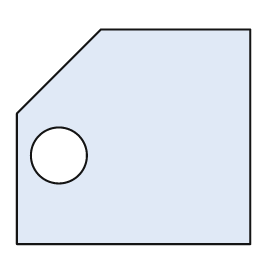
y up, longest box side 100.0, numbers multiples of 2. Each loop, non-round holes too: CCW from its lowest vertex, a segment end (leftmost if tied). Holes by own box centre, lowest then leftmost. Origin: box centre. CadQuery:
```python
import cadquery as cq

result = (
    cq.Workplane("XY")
    .moveTo(-50.0, -46.0)
    .lineTo(50.0, -46.0)
    .lineTo(50.0, 46.0)
    .lineTo(-14.0, 46.0)
    .lineTo(-50.0, 10.0)
    .close()
    .moveTo(-32.0, -8.0)
    .circle(12.0)
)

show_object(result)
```